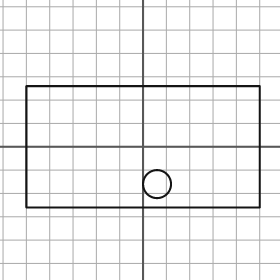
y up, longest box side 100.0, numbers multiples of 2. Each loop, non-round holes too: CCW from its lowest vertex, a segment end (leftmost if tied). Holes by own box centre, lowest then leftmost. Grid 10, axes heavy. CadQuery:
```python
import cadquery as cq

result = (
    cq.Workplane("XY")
    .moveTo(-50.0, -26.0)
    .lineTo(50.0, -26.0)
    .lineTo(50.0, 26.0)
    .lineTo(-50.0, 26.0)
    .close()
    .moveTo(6.0, -16.0)
    .circle(6.0)
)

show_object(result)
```